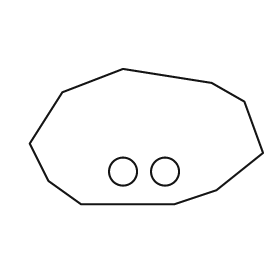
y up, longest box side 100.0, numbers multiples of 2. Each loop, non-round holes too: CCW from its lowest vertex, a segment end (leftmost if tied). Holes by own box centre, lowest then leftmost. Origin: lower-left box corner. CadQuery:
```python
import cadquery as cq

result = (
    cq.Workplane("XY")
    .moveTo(22.0, 0.0)
    .lineTo(62.0, 0.0)
    .lineTo(80.0, 6.0)
    .lineTo(100.0, 22.0)
    .lineTo(92.0, 44.0)
    .lineTo(78.0, 52.0)
    .lineTo(40.0, 58.0)
    .lineTo(14.0, 48.0)
    .lineTo(0.0, 26.0)
    .lineTo(8.0, 10.0)
    .close()
    .moveTo(40.0, 14.0)
    .circle(6.0)
    .moveTo(58.0, 14.0)
    .circle(6.0)
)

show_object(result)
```